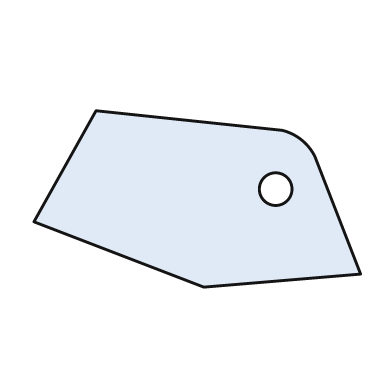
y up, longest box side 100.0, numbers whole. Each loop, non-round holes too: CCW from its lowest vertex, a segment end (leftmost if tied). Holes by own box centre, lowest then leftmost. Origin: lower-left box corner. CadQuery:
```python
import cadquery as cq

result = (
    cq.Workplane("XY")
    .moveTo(52.0, 0.0)
    .lineTo(100.0, 4.0)
    .lineTo(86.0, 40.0)
    .threePointArc((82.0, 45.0), (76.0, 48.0))
    .lineTo(19.0, 54.0)
    .lineTo(0.0, 20.0)
    .close()
    .moveTo(74.0, 30.0)
    .circle(5.0)
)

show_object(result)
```